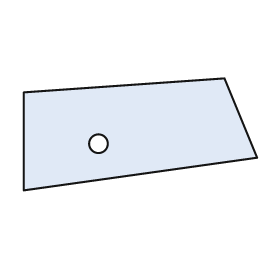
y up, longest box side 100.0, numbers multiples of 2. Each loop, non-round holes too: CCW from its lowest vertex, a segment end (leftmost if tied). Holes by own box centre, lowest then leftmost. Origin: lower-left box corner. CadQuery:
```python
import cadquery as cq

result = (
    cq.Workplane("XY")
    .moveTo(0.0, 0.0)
    .lineTo(100.0, 14.0)
    .lineTo(86.0, 48.0)
    .lineTo(0.0, 42.0)
    .close()
    .moveTo(32.0, 20.0)
    .circle(4.0)
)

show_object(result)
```